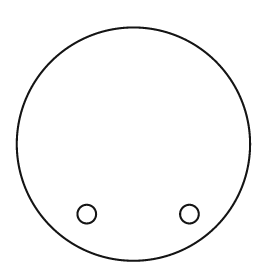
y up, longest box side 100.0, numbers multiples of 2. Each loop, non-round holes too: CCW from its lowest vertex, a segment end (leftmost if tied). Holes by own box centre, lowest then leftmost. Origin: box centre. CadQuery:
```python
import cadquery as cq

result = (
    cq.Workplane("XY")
    .moveTo(0.0, 0.0)
    .circle(50.0)
    .moveTo(-20.0, -30.0)
    .circle(4.0)
    .moveTo(24.0, -30.0)
    .circle(4.0)
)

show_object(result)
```